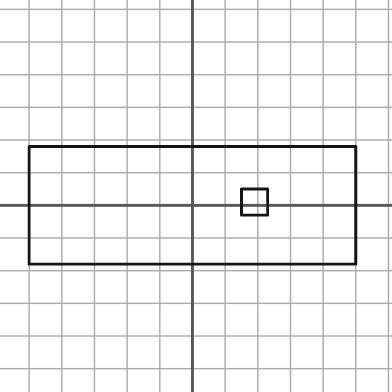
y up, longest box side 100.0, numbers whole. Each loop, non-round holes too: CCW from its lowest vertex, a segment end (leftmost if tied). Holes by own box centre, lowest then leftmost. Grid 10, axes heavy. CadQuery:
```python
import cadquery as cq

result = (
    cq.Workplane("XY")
    .moveTo(-50.0, -18.0)
    .lineTo(50.0, -18.0)
    .lineTo(50.0, 18.0)
    .lineTo(-50.0, 18.0)
    .close()
    .moveTo(15.0, -3.0)
    .lineTo(23.0, -3.0)
    .lineTo(23.0, 5.0)
    .lineTo(15.0, 5.0)
    .close()
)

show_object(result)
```